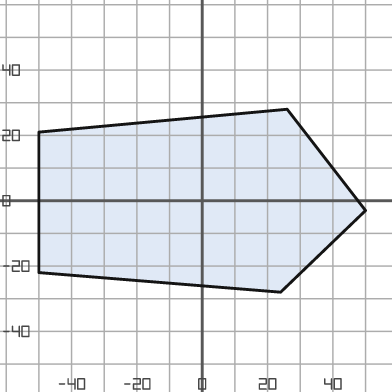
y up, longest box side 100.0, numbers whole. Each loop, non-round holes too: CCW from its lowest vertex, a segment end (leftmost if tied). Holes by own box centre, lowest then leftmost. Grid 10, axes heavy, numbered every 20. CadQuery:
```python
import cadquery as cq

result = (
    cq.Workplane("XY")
    .moveTo(24.0, -28.0)
    .lineTo(50.0, -3.0)
    .lineTo(26.0, 28.0)
    .lineTo(-50.0, 21.0)
    .lineTo(-50.0, -22.0)
    .close()
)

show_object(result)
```